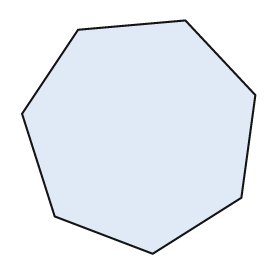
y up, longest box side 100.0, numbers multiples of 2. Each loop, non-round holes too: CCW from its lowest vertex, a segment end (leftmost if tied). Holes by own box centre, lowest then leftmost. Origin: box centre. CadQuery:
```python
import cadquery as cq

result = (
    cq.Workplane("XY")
    .moveTo(6.0, -50.0)
    .lineTo(44.0, -26.0)
    .lineTo(50.0, 18.0)
    .lineTo(20.0, 50.0)
    .lineTo(-26.0, 46.0)
    .lineTo(-50.0, 10.0)
    .lineTo(-36.0, -34.0)
    .close()
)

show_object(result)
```